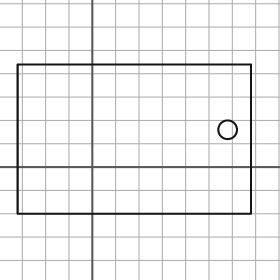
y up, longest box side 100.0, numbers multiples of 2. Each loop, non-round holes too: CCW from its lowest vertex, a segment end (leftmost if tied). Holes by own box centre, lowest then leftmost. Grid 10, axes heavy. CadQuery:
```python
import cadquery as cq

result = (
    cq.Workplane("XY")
    .moveTo(-32.0, -20.0)
    .lineTo(68.0, -20.0)
    .lineTo(68.0, 44.0)
    .lineTo(-32.0, 44.0)
    .close()
    .moveTo(58.0, 16.0)
    .circle(4.0)
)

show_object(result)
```